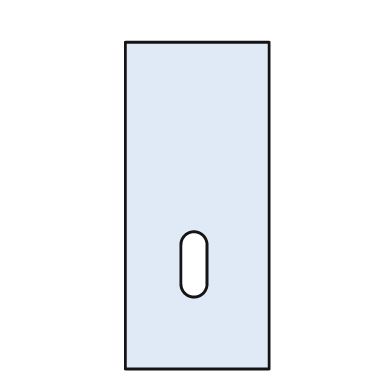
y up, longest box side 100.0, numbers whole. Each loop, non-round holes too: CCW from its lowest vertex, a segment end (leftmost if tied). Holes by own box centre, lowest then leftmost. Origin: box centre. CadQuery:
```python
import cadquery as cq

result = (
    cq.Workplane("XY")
    .moveTo(-22.0, -50.0)
    .lineTo(22.0, -50.0)
    .lineTo(22.0, 50.0)
    .lineTo(-22.0, 50.0)
    .close()
    .moveTo(-5.0, -24.0)
    .threePointArc((-1.0, -28.0), (3.0, -24.0))
    .lineTo(3.0, -12.0)
    .threePointArc((-1.0, -8.0), (-5.0, -12.0))
    .close()
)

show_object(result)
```